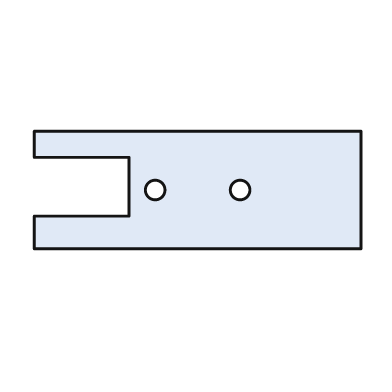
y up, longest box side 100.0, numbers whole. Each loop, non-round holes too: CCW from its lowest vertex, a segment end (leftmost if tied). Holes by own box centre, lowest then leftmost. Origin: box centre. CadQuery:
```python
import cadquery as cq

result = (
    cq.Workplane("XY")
    .moveTo(-50.0, -18.0)
    .lineTo(50.0, -18.0)
    .lineTo(50.0, 18.0)
    .lineTo(-50.0, 18.0)
    .lineTo(-50.0, 10.0)
    .lineTo(-21.0, 10.0)
    .lineTo(-21.0, -8.0)
    .lineTo(-50.0, -8.0)
    .close()
    .moveTo(-13.0, 0.0)
    .circle(3.0)
    .moveTo(13.0, 0.0)
    .circle(3.0)
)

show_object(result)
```